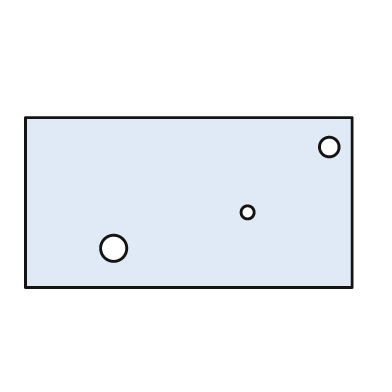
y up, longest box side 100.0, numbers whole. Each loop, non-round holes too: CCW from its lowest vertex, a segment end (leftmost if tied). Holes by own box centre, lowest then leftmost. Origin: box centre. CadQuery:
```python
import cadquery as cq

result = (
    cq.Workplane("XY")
    .moveTo(-50.0, -26.0)
    .lineTo(50.0, -26.0)
    .lineTo(50.0, 26.0)
    .lineTo(-50.0, 26.0)
    .close()
    .moveTo(-23.0, -14.0)
    .circle(4.0)
    .moveTo(18.0, -3.0)
    .circle(2.0)
    .moveTo(43.0, 17.0)
    .circle(3.0)
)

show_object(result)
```